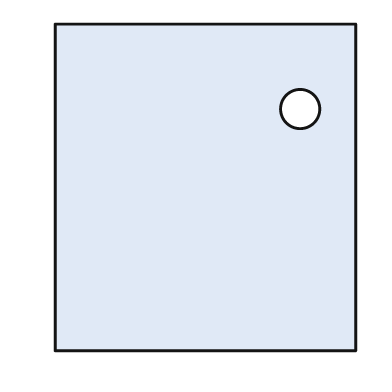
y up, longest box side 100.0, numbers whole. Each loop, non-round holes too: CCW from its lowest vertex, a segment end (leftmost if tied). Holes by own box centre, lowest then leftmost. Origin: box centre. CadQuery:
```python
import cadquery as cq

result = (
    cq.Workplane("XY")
    .moveTo(-46.0, -50.0)
    .lineTo(46.0, -50.0)
    .lineTo(46.0, 50.0)
    .lineTo(-46.0, 50.0)
    .close()
    .moveTo(29.0, 24.0)
    .circle(6.0)
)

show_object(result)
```